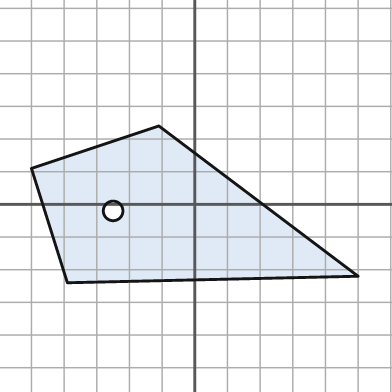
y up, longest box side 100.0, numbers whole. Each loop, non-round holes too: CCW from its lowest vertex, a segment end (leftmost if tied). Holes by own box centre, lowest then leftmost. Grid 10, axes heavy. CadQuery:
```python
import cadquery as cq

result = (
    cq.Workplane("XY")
    .moveTo(-39.0, -24.0)
    .lineTo(50.0, -22.0)
    .lineTo(-11.0, 24.0)
    .lineTo(-50.0, 11.0)
    .close()
    .moveTo(-25.0, -2.0)
    .circle(3.0)
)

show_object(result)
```